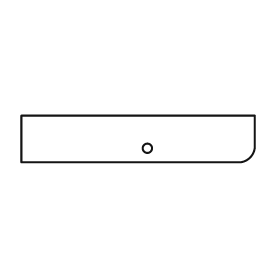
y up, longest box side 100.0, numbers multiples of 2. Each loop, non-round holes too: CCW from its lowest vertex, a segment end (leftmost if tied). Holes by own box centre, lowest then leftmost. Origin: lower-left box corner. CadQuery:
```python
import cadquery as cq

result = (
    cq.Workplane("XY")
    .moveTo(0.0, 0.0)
    .lineTo(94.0, 0.0)
    .threePointArc((98.0, 2.0), (100.0, 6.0))
    .lineTo(100.0, 20.0)
    .lineTo(0.0, 20.0)
    .close()
    .moveTo(54.0, 6.0)
    .circle(2.0)
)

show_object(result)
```